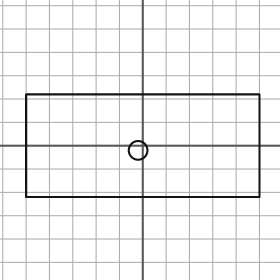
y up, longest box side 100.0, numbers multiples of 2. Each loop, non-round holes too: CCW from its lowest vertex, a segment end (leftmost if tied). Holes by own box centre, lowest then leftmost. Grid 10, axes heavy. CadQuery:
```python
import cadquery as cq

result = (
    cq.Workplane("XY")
    .moveTo(-50.0, -22.0)
    .lineTo(50.0, -22.0)
    .lineTo(50.0, 22.0)
    .lineTo(-50.0, 22.0)
    .close()
    .moveTo(-2.0, -2.0)
    .circle(4.0)
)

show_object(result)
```